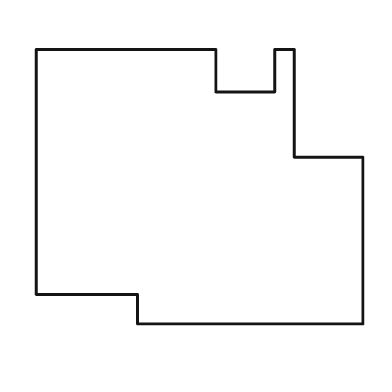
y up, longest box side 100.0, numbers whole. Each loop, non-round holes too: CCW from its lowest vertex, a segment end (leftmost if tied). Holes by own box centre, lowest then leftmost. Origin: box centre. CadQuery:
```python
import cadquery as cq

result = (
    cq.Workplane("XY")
    .moveTo(-19.0, -42.0)
    .lineTo(50.0, -42.0)
    .lineTo(50.0, 9.0)
    .lineTo(29.0, 9.0)
    .lineTo(29.0, 42.0)
    .lineTo(23.0, 42.0)
    .lineTo(23.0, 29.0)
    .lineTo(5.0, 29.0)
    .lineTo(5.0, 42.0)
    .lineTo(-50.0, 42.0)
    .lineTo(-50.0, -33.0)
    .lineTo(-19.0, -33.0)
    .close()
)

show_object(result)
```